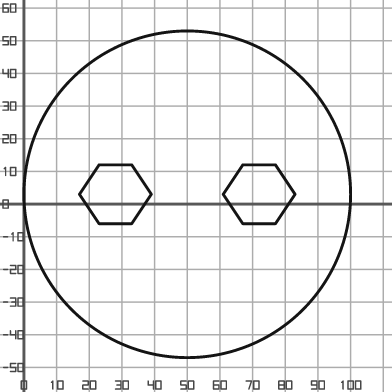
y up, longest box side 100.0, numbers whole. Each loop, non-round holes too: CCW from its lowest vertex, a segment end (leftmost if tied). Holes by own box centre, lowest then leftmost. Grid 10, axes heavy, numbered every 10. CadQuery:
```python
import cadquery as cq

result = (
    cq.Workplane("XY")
    .moveTo(50.0, 3.0)
    .circle(50.0)
    .moveTo(23.0, -6.0)
    .lineTo(33.0, -6.0)
    .lineTo(39.0, 3.0)
    .lineTo(33.0, 12.0)
    .lineTo(23.0, 12.0)
    .lineTo(17.0, 3.0)
    .close()
    .moveTo(67.0, -6.0)
    .lineTo(77.0, -6.0)
    .lineTo(83.0, 3.0)
    .lineTo(77.0, 12.0)
    .lineTo(67.0, 12.0)
    .lineTo(61.0, 3.0)
    .close()
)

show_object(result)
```